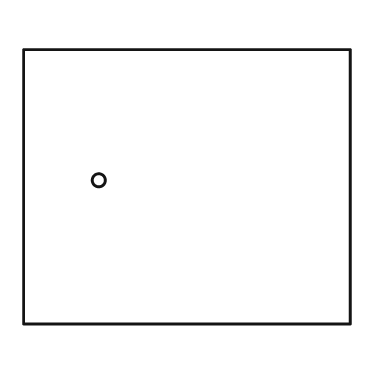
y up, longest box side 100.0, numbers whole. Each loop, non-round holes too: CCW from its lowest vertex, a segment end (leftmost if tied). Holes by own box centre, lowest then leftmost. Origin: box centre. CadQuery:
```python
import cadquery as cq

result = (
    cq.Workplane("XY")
    .moveTo(-50.0, -42.0)
    .lineTo(50.0, -42.0)
    .lineTo(50.0, 42.0)
    .lineTo(-50.0, 42.0)
    .close()
    .moveTo(-27.0, 2.0)
    .circle(2.0)
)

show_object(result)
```